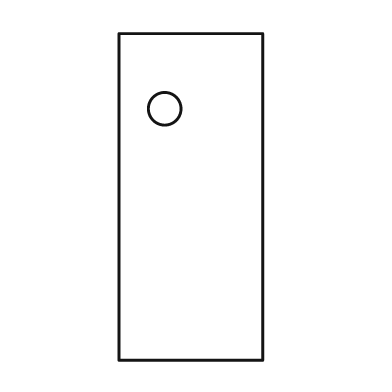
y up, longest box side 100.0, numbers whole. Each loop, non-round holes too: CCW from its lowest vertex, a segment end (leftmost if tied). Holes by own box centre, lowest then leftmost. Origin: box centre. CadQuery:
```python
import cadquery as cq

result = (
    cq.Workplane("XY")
    .moveTo(-22.0, -50.0)
    .lineTo(22.0, -50.0)
    .lineTo(22.0, 50.0)
    .lineTo(-22.0, 50.0)
    .close()
    .moveTo(-8.0, 27.0)
    .circle(5.0)
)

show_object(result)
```